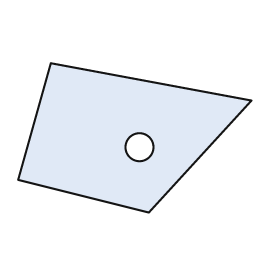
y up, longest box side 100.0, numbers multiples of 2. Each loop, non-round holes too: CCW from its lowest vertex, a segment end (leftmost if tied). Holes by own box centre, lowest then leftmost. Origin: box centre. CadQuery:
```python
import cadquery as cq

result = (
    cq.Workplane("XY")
    .moveTo(6.0, -32.0)
    .lineTo(50.0, 16.0)
    .lineTo(-36.0, 32.0)
    .lineTo(-50.0, -18.0)
    .close()
    .moveTo(2.0, -4.0)
    .circle(6.0)
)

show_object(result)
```